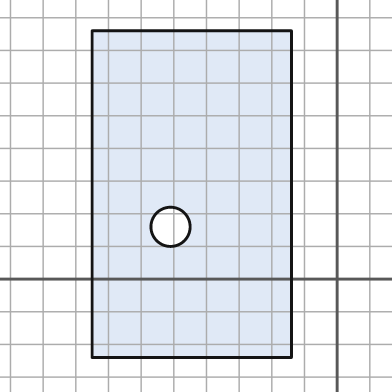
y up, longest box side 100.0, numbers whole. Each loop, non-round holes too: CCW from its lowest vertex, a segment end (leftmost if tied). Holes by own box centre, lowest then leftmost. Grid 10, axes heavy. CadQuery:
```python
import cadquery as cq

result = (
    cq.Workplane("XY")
    .moveTo(-75.0, -24.0)
    .lineTo(-14.0, -24.0)
    .lineTo(-14.0, 76.0)
    .lineTo(-75.0, 76.0)
    .close()
    .moveTo(-51.0, 16.0)
    .circle(6.0)
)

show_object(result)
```